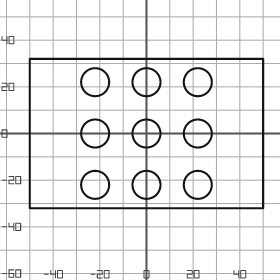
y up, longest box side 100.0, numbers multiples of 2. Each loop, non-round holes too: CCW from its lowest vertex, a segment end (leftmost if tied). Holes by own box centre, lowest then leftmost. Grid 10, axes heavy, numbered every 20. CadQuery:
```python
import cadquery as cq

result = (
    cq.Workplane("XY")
    .moveTo(-50.0, -32.0)
    .lineTo(50.0, -32.0)
    .lineTo(50.0, 32.0)
    .lineTo(-50.0, 32.0)
    .close()
    .moveTo(-22.0, -22.0)
    .circle(6.0)
    .moveTo(0.0, -22.0)
    .circle(6.0)
    .moveTo(22.0, -22.0)
    .circle(6.0)
    .moveTo(-22.0, 0.0)
    .circle(6.0)
    .moveTo(0.0, 0.0)
    .circle(6.0)
    .moveTo(22.0, 0.0)
    .circle(6.0)
    .moveTo(-22.0, 22.0)
    .circle(6.0)
    .moveTo(0.0, 22.0)
    .circle(6.0)
    .moveTo(22.0, 22.0)
    .circle(6.0)
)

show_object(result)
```